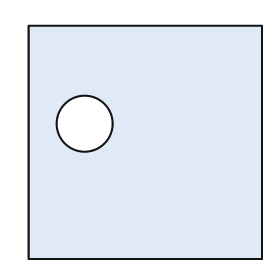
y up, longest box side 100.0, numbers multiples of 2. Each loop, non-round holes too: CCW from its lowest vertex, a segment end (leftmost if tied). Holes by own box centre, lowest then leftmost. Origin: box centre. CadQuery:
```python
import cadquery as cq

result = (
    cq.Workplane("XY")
    .moveTo(-50.0, -50.0)
    .lineTo(50.0, -50.0)
    .lineTo(50.0, 50.0)
    .lineTo(-50.0, 50.0)
    .close()
    .moveTo(-26.0, 8.0)
    .circle(12.0)
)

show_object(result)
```